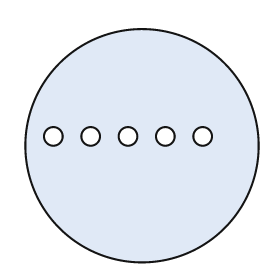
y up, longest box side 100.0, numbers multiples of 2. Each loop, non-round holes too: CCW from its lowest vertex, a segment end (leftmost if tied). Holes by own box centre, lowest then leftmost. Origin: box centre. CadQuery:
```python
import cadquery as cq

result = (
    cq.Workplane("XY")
    .moveTo(0.0, 0.0)
    .circle(50.0)
    .moveTo(-38.0, 4.0)
    .circle(4.0)
    .moveTo(-22.0, 4.0)
    .circle(4.0)
    .moveTo(-6.0, 4.0)
    .circle(4.0)
    .moveTo(10.0, 4.0)
    .circle(4.0)
    .moveTo(26.0, 4.0)
    .circle(4.0)
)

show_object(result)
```